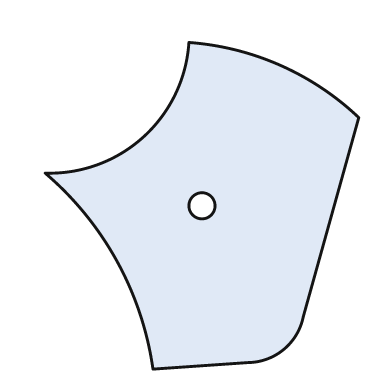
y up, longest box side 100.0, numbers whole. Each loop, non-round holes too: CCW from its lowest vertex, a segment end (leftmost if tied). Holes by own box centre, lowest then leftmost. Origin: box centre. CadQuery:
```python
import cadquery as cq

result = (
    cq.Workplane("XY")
    .moveTo(-15.0, -50.0)
    .lineTo(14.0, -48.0)
    .threePointArc((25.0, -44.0), (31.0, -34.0))
    .lineTo(48.0, 27.0)
    .threePointArc((24.0, 43.0), (-4.0, 50.0))
    .threePointArc((-18.0, 21.0), (-48.0, 10.0))
    .threePointArc((-26.0, -17.0), (-15.0, -50.0))
    .close()
    .moveTo(0.0, 0.0)
    .circle(4.0)
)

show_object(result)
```